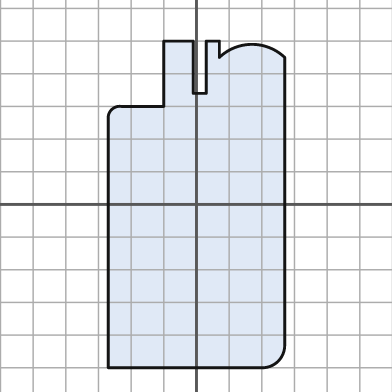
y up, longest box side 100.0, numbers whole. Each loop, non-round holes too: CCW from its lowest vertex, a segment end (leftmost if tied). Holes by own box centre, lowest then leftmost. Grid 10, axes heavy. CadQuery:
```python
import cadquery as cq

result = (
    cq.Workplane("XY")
    .moveTo(-27.0, -50.0)
    .lineTo(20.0, -50.0)
    .threePointArc((25.0, -48.0), (27.0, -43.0))
    .lineTo(27.0, 45.0)
    .threePointArc((17.0, 49.0), (7.0, 45.0))
    .lineTo(7.0, 50.0)
    .lineTo(3.0, 50.0)
    .lineTo(3.0, 34.0)
    .lineTo(-1.0, 34.0)
    .lineTo(-1.0, 50.0)
    .lineTo(-10.0, 50.0)
    .lineTo(-10.0, 30.0)
    .lineTo(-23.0, 30.0)
    .threePointArc((-26.0, 29.0), (-27.0, 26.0))
    .close()
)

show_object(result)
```